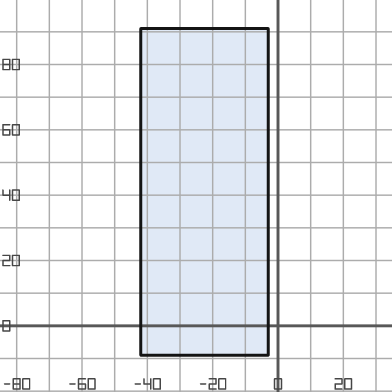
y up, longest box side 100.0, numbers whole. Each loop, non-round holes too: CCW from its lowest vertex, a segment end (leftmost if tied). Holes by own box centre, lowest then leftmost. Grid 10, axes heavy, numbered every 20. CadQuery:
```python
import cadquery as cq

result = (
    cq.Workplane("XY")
    .moveTo(-42.0, -9.0)
    .lineTo(-3.0, -9.0)
    .lineTo(-3.0, 91.0)
    .lineTo(-42.0, 91.0)
    .close()
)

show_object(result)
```